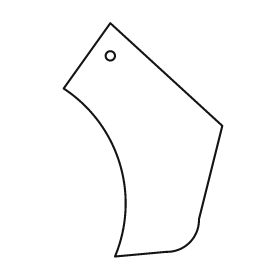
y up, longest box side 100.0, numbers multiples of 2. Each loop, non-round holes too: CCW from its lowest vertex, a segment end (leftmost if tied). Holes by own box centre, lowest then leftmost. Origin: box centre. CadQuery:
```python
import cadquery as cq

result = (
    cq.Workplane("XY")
    .moveTo(-12.0, -50.0)
    .lineTo(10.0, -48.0)
    .threePointArc((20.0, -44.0), (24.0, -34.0))
    .lineTo(34.0, 6.0)
    .lineTo(-14.0, 50.0)
    .lineTo(-34.0, 22.0)
    .threePointArc((-10.0, -10.0), (-12.0, -50.0))
    .close()
    .moveTo(-14.0, 36.0)
    .circle(2.0)
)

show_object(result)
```